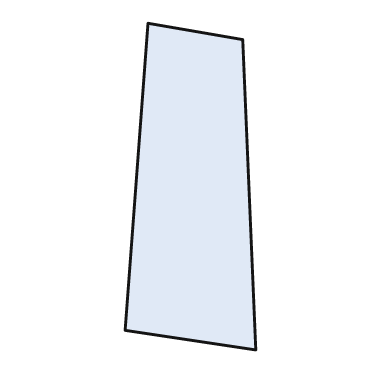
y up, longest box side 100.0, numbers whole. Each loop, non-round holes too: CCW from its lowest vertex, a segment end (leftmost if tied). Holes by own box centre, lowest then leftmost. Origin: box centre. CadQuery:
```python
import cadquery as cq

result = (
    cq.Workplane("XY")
    .moveTo(20.0, -50.0)
    .lineTo(16.0, 45.0)
    .lineTo(-13.0, 50.0)
    .lineTo(-20.0, -44.0)
    .close()
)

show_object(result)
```